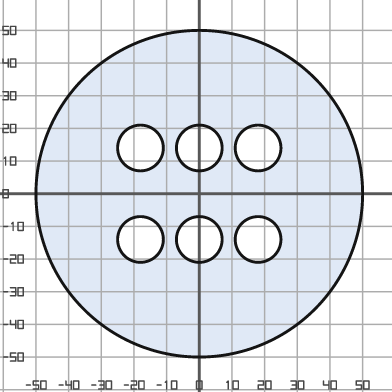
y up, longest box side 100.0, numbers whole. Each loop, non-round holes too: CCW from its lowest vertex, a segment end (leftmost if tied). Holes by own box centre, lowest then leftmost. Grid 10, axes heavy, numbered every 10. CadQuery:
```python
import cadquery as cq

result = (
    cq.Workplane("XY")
    .moveTo(0.0, 0.0)
    .circle(50.0)
    .moveTo(-18.0, -14.0)
    .circle(7.0)
    .moveTo(0.0, -14.0)
    .circle(7.0)
    .moveTo(18.0, -14.0)
    .circle(7.0)
    .moveTo(-18.0, 14.0)
    .circle(7.0)
    .moveTo(0.0, 14.0)
    .circle(7.0)
    .moveTo(18.0, 14.0)
    .circle(7.0)
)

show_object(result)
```